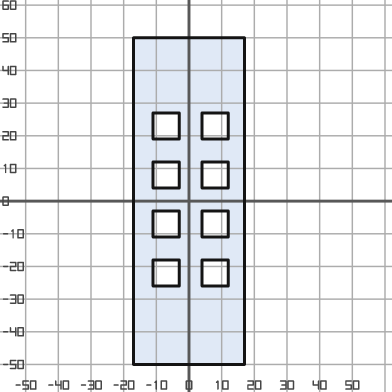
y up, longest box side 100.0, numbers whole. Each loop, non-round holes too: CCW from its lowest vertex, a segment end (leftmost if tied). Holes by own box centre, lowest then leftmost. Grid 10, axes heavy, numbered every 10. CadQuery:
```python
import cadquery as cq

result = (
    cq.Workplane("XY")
    .moveTo(-17.0, -50.0)
    .lineTo(17.0, -50.0)
    .lineTo(17.0, 50.0)
    .lineTo(-17.0, 50.0)
    .close()
    .moveTo(-11.0, -26.0)
    .lineTo(-3.0, -26.0)
    .lineTo(-3.0, -18.0)
    .lineTo(-11.0, -18.0)
    .close()
    .moveTo(4.0, -26.0)
    .lineTo(12.0, -26.0)
    .lineTo(12.0, -18.0)
    .lineTo(4.0, -18.0)
    .close()
    .moveTo(-11.0, -11.0)
    .lineTo(-3.0, -11.0)
    .lineTo(-3.0, -3.0)
    .lineTo(-11.0, -3.0)
    .close()
    .moveTo(4.0, -11.0)
    .lineTo(12.0, -11.0)
    .lineTo(12.0, -3.0)
    .lineTo(4.0, -3.0)
    .close()
    .moveTo(-11.0, 4.0)
    .lineTo(-3.0, 4.0)
    .lineTo(-3.0, 12.0)
    .lineTo(-11.0, 12.0)
    .close()
    .moveTo(4.0, 4.0)
    .lineTo(12.0, 4.0)
    .lineTo(12.0, 12.0)
    .lineTo(4.0, 12.0)
    .close()
    .moveTo(-11.0, 19.0)
    .lineTo(-3.0, 19.0)
    .lineTo(-3.0, 27.0)
    .lineTo(-11.0, 27.0)
    .close()
    .moveTo(4.0, 19.0)
    .lineTo(12.0, 19.0)
    .lineTo(12.0, 27.0)
    .lineTo(4.0, 27.0)
    .close()
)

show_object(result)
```